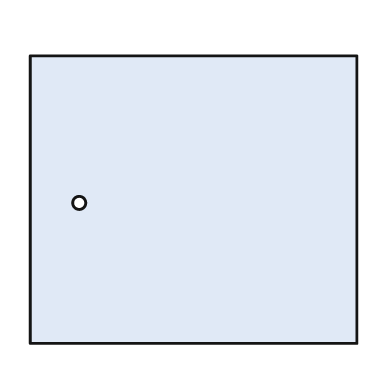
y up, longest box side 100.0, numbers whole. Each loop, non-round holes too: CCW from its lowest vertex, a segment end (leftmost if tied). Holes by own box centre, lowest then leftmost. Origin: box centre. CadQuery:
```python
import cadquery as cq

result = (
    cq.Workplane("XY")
    .moveTo(-50.0, -44.0)
    .lineTo(50.0, -44.0)
    .lineTo(50.0, 44.0)
    .lineTo(-50.0, 44.0)
    .close()
    .moveTo(-35.0, -1.0)
    .circle(2.0)
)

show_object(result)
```